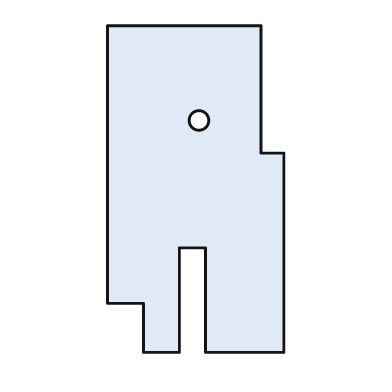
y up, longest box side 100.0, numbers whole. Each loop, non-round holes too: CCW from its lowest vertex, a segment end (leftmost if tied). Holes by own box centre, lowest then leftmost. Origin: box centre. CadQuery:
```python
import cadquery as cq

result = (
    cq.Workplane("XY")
    .moveTo(-16.0, -50.0)
    .lineTo(-5.0, -50.0)
    .lineTo(-5.0, -18.0)
    .lineTo(3.0, -18.0)
    .lineTo(3.0, -50.0)
    .lineTo(27.0, -50.0)
    .lineTo(27.0, 11.0)
    .lineTo(20.0, 11.0)
    .lineTo(20.0, 50.0)
    .lineTo(-27.0, 50.0)
    .lineTo(-27.0, -35.0)
    .lineTo(-16.0, -35.0)
    .close()
    .moveTo(1.0, 21.0)
    .circle(3.0)
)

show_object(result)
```